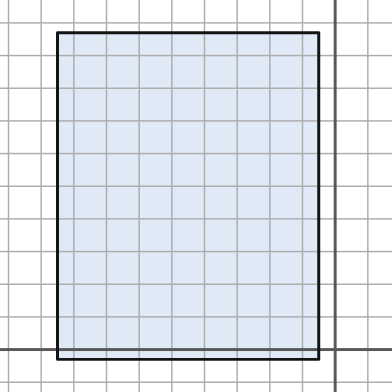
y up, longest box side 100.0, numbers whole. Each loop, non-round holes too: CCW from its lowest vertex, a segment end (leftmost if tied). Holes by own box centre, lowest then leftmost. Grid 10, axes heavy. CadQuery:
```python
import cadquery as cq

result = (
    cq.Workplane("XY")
    .moveTo(-85.0, -3.0)
    .lineTo(-5.0, -3.0)
    .lineTo(-5.0, 97.0)
    .lineTo(-85.0, 97.0)
    .close()
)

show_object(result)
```